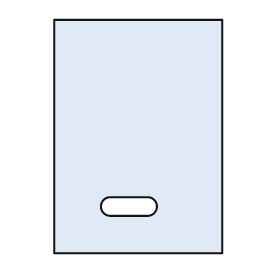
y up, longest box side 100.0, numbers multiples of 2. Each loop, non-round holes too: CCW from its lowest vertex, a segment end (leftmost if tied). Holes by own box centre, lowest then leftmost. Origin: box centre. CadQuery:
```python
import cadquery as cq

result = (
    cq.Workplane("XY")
    .moveTo(-36.0, -50.0)
    .lineTo(36.0, -50.0)
    .lineTo(36.0, 50.0)
    .lineTo(-36.0, 50.0)
    .close()
    .moveTo(-12.0, -34.0)
    .lineTo(4.0, -34.0)
    .threePointArc((8.0, -30.0), (4.0, -26.0))
    .lineTo(-12.0, -26.0)
    .threePointArc((-16.0, -30.0), (-12.0, -34.0))
    .close()
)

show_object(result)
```